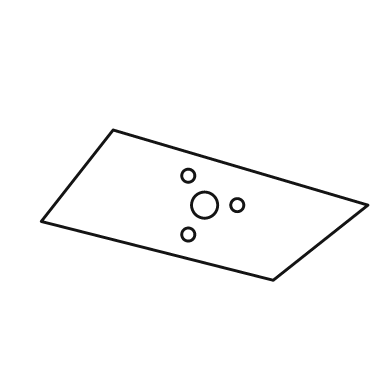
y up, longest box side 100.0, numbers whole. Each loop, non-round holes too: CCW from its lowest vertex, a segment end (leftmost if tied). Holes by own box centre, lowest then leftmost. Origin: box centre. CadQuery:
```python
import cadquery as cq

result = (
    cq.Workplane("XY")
    .moveTo(21.0, -23.0)
    .lineTo(50.0, 0.0)
    .lineTo(-28.0, 23.0)
    .lineTo(-50.0, -5.0)
    .close()
    .moveTo(-5.0, -9.0)
    .circle(2.0)
    .moveTo(0.0, 0.0)
    .circle(4.0)
    .moveTo(10.0, 0.0)
    .circle(2.0)
    .moveTo(-5.0, 9.0)
    .circle(2.0)
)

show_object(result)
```